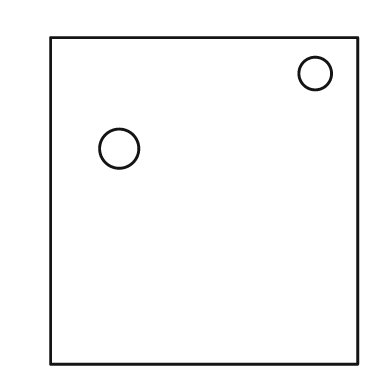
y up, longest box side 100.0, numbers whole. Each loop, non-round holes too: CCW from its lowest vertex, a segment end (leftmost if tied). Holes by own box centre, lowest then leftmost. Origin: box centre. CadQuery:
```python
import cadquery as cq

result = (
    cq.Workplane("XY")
    .moveTo(-47.0, -50.0)
    .lineTo(47.0, -50.0)
    .lineTo(47.0, 50.0)
    .lineTo(-47.0, 50.0)
    .close()
    .moveTo(-26.0, 16.0)
    .circle(6.0)
    .moveTo(34.0, 39.0)
    .circle(5.0)
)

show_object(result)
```